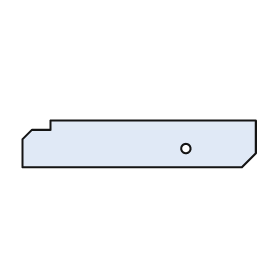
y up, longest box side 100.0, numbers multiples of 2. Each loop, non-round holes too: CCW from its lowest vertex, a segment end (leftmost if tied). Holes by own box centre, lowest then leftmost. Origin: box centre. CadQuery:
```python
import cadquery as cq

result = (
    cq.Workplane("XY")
    .moveTo(-50.0, -10.0)
    .lineTo(44.0, -10.0)
    .lineTo(50.0, -4.0)
    .lineTo(50.0, 10.0)
    .lineTo(-38.0, 10.0)
    .lineTo(-38.0, 6.0)
    .lineTo(-46.0, 6.0)
    .lineTo(-50.0, 2.0)
    .close()
    .moveTo(20.0, -2.0)
    .circle(2.0)
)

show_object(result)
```